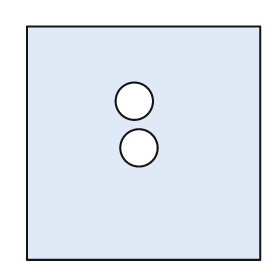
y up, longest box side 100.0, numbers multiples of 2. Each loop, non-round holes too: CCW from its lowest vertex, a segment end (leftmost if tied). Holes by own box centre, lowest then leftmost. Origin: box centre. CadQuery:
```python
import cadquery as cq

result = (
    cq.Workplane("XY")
    .moveTo(-50.0, -50.0)
    .lineTo(50.0, -50.0)
    .lineTo(50.0, 50.0)
    .lineTo(-50.0, 50.0)
    .close()
    .moveTo(-2.0, -2.0)
    .circle(8.0)
    .moveTo(-4.0, 18.0)
    .circle(8.0)
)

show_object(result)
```